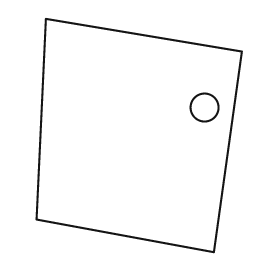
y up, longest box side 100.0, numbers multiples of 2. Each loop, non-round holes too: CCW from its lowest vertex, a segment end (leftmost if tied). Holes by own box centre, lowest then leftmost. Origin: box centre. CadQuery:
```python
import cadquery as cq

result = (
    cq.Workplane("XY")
    .moveTo(32.0, -50.0)
    .lineTo(44.0, 36.0)
    .lineTo(-40.0, 50.0)
    .lineTo(-44.0, -36.0)
    .close()
    .moveTo(28.0, 12.0)
    .circle(6.0)
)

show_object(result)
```